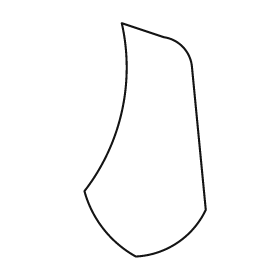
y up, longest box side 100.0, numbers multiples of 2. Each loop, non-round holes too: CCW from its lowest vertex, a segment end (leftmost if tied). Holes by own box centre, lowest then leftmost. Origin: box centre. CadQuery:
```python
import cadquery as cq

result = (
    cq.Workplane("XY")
    .moveTo(-4.0, -50.0)
    .threePointArc((14.0, -44.0), (26.0, -30.0))
    .lineTo(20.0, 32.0)
    .threePointArc((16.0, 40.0), (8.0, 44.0))
    .lineTo(-10.0, 50.0)
    .threePointArc((-10.0, 12.0), (-26.0, -22.0))
    .threePointArc((-18.0, -38.0), (-4.0, -50.0))
    .close()
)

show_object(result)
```